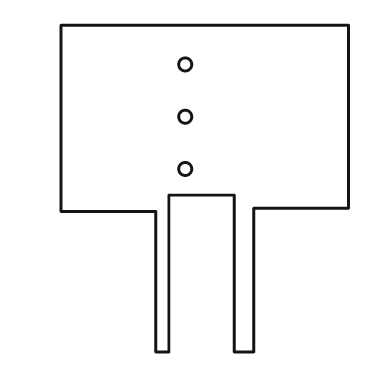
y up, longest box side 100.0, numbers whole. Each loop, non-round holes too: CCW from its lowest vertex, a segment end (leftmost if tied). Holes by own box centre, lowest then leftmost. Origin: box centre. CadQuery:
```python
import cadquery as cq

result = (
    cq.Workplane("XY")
    .moveTo(-15.0, -50.0)
    .lineTo(-11.0, -50.0)
    .lineTo(-11.0, -2.0)
    .lineTo(9.0, -2.0)
    .lineTo(9.0, -50.0)
    .lineTo(15.0, -50.0)
    .lineTo(15.0, -6.0)
    .lineTo(44.0, -6.0)
    .lineTo(44.0, 50.0)
    .lineTo(-44.0, 50.0)
    .lineTo(-44.0, -7.0)
    .lineTo(-15.0, -7.0)
    .close()
    .moveTo(-6.0, 6.0)
    .circle(2.0)
    .moveTo(-6.0, 22.0)
    .circle(2.0)
    .moveTo(-6.0, 38.0)
    .circle(2.0)
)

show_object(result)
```